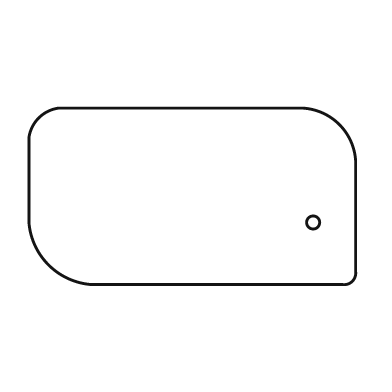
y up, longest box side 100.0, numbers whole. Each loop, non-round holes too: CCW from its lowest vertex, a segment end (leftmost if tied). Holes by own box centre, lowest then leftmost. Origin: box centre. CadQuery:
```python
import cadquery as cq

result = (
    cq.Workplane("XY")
    .moveTo(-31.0, -27.0)
    .lineTo(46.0, -27.0)
    .threePointArc((49.0, -26.0), (50.0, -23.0))
    .lineTo(50.0, 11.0)
    .threePointArc((45.0, 22.0), (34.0, 27.0))
    .lineTo(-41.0, 27.0)
    .threePointArc((-47.0, 24.0), (-50.0, 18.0))
    .lineTo(-50.0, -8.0)
    .threePointArc((-44.0, -21.0), (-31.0, -27.0))
    .close()
    .moveTo(37.0, -8.0)
    .circle(2.0)
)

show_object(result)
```